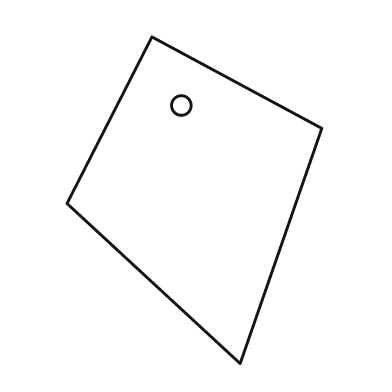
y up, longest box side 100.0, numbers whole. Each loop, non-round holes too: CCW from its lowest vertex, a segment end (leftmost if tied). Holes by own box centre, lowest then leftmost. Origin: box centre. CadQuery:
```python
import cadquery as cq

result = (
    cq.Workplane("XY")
    .moveTo(14.0, -50.0)
    .lineTo(39.0, 22.0)
    .lineTo(-13.0, 50.0)
    .lineTo(-39.0, -1.0)
    .close()
    .moveTo(-4.0, 29.0)
    .circle(3.0)
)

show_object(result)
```